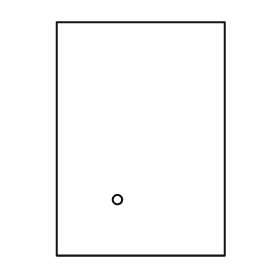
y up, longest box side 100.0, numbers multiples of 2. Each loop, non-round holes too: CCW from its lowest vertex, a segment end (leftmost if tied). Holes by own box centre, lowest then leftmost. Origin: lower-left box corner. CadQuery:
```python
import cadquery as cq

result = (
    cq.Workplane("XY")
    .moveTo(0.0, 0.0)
    .lineTo(72.0, 0.0)
    .lineTo(72.0, 100.0)
    .lineTo(0.0, 100.0)
    .close()
    .moveTo(26.0, 24.0)
    .circle(2.0)
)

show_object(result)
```